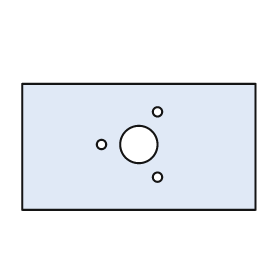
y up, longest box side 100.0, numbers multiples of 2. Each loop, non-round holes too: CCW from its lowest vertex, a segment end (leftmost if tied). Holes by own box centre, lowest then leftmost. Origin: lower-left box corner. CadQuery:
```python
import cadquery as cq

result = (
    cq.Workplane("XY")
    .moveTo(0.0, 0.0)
    .lineTo(100.0, 0.0)
    .lineTo(100.0, 54.0)
    .lineTo(0.0, 54.0)
    .close()
    .moveTo(58.0, 14.0)
    .circle(2.0)
    .moveTo(34.0, 28.0)
    .circle(2.0)
    .moveTo(50.0, 28.0)
    .circle(8.0)
    .moveTo(58.0, 42.0)
    .circle(2.0)
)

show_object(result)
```